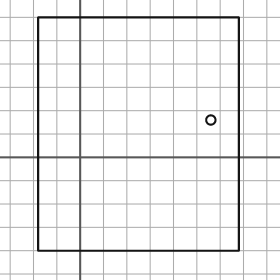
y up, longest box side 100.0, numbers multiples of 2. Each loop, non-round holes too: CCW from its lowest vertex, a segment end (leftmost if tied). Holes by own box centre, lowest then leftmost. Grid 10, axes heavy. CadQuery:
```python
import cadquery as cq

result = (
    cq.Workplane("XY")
    .moveTo(-18.0, -40.0)
    .lineTo(68.0, -40.0)
    .lineTo(68.0, 60.0)
    .lineTo(-18.0, 60.0)
    .close()
    .moveTo(56.0, 16.0)
    .circle(2.0)
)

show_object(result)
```